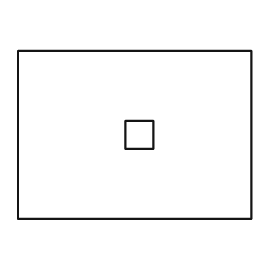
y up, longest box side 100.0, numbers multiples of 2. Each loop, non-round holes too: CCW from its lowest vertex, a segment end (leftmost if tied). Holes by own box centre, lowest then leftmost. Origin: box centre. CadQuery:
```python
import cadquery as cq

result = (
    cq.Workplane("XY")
    .moveTo(-50.0, -36.0)
    .lineTo(50.0, -36.0)
    .lineTo(50.0, 36.0)
    .lineTo(-50.0, 36.0)
    .close()
    .moveTo(-4.0, -6.0)
    .lineTo(8.0, -6.0)
    .lineTo(8.0, 6.0)
    .lineTo(-4.0, 6.0)
    .close()
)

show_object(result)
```